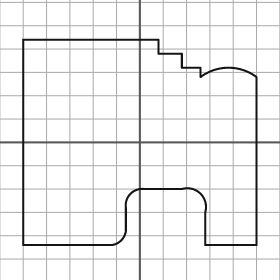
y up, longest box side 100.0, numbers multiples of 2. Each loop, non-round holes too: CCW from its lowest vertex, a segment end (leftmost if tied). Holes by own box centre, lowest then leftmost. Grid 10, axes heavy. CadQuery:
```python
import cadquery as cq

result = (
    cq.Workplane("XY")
    .moveTo(-50.0, -44.0)
    .lineTo(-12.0, -44.0)
    .threePointArc((-8.0, -42.0), (-6.0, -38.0))
    .lineTo(-6.0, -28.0)
    .threePointArc((-4.0, -22.0), (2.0, -20.0))
    .lineTo(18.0, -20.0)
    .threePointArc((26.0, -22.0), (28.0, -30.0))
    .lineTo(28.0, -44.0)
    .lineTo(50.0, -44.0)
    .lineTo(50.0, 28.0)
    .threePointArc((38.0, 32.0), (26.0, 28.0))
    .lineTo(26.0, 32.0)
    .lineTo(18.0, 32.0)
    .lineTo(18.0, 38.0)
    .lineTo(8.0, 38.0)
    .lineTo(8.0, 44.0)
    .lineTo(-50.0, 44.0)
    .close()
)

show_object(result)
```